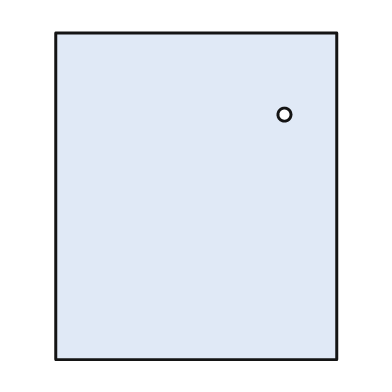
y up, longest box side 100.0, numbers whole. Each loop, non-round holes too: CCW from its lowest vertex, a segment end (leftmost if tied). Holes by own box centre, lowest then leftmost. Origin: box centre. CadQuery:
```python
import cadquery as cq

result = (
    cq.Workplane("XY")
    .moveTo(-43.0, -50.0)
    .lineTo(43.0, -50.0)
    .lineTo(43.0, 50.0)
    .lineTo(-43.0, 50.0)
    .close()
    .moveTo(27.0, 25.0)
    .circle(2.0)
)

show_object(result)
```